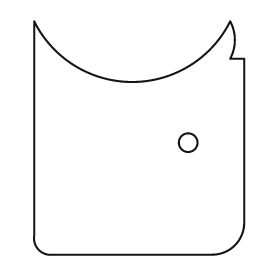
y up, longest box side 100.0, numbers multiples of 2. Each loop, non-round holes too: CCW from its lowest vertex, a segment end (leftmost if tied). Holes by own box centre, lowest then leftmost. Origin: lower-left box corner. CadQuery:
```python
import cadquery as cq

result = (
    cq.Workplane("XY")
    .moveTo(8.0, 0.0)
    .lineTo(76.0, 0.0)
    .threePointArc((86.0, 4.0), (90.0, 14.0))
    .lineTo(90.0, 84.0)
    .lineTo(84.0, 84.0)
    .threePointArc((86.0, 92.0), (84.0, 100.0))
    .threePointArc((42.0, 74.0), (0.0, 100.0))
    .lineTo(0.0, 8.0)
    .threePointArc((2.0, 2.0), (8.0, 0.0))
    .close()
    .moveTo(66.0, 48.0)
    .circle(4.0)
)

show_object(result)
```